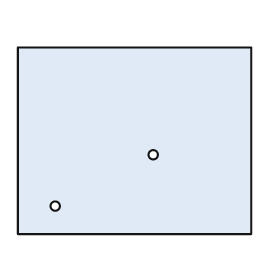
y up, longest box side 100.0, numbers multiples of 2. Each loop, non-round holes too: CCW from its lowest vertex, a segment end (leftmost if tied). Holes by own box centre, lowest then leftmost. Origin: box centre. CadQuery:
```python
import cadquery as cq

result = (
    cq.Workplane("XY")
    .moveTo(-50.0, -40.0)
    .lineTo(50.0, -40.0)
    .lineTo(50.0, 40.0)
    .lineTo(-50.0, 40.0)
    .close()
    .moveTo(-34.0, -28.0)
    .circle(2.0)
    .moveTo(8.0, -6.0)
    .circle(2.0)
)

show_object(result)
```